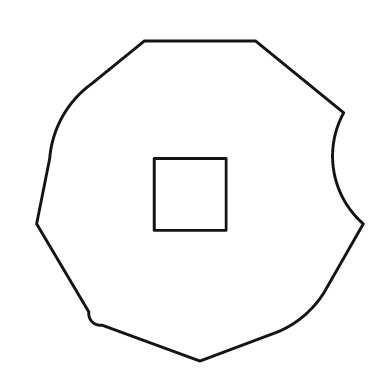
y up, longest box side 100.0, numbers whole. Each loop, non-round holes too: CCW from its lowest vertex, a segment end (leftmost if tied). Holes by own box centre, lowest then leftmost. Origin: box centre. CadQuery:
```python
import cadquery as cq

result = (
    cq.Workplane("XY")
    .moveTo(0.0, -49.0)
    .lineTo(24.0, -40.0)
    .threePointArc((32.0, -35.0), (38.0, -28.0))
    .lineTo(50.0, -7.0)
    .threePointArc((41.0, 9.0), (44.0, 27.0))
    .lineTo(17.0, 49.0)
    .lineTo(-17.0, 49.0)
    .lineTo(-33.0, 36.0)
    .threePointArc((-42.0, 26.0), (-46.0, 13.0))
    .lineTo(-50.0, -7.0)
    .lineTo(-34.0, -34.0)
    .threePointArc((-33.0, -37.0), (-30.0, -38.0))
    .close()
    .moveTo(-14.0, -9.0)
    .lineTo(8.0, -9.0)
    .lineTo(8.0, 13.0)
    .lineTo(-14.0, 13.0)
    .close()
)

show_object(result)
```